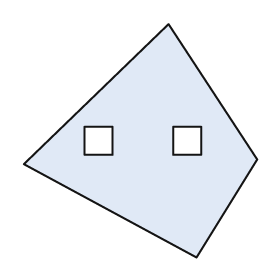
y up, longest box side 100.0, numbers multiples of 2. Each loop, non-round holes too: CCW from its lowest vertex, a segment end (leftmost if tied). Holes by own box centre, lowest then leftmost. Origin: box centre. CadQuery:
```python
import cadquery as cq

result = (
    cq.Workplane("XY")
    .moveTo(24.0, -50.0)
    .lineTo(50.0, -8.0)
    .lineTo(12.0, 50.0)
    .lineTo(-50.0, -10.0)
    .close()
    .moveTo(-24.0, -6.0)
    .lineTo(-12.0, -6.0)
    .lineTo(-12.0, 6.0)
    .lineTo(-24.0, 6.0)
    .close()
    .moveTo(14.0, -6.0)
    .lineTo(26.0, -6.0)
    .lineTo(26.0, 6.0)
    .lineTo(14.0, 6.0)
    .close()
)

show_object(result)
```